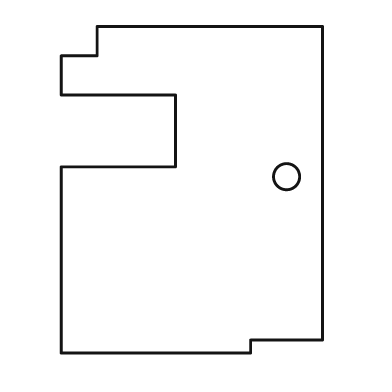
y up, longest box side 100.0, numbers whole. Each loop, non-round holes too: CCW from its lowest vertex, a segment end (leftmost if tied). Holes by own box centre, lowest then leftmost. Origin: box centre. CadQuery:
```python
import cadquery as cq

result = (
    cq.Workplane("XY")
    .moveTo(-40.0, -50.0)
    .lineTo(18.0, -50.0)
    .lineTo(18.0, -46.0)
    .lineTo(40.0, -46.0)
    .lineTo(40.0, 50.0)
    .lineTo(-29.0, 50.0)
    .lineTo(-29.0, 41.0)
    .lineTo(-40.0, 41.0)
    .lineTo(-40.0, 29.0)
    .lineTo(-5.0, 29.0)
    .lineTo(-5.0, 7.0)
    .lineTo(-40.0, 7.0)
    .close()
    .moveTo(29.0, 4.0)
    .circle(4.0)
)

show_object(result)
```